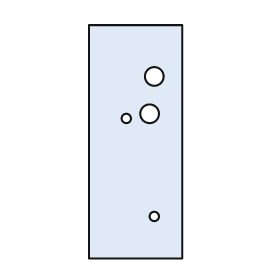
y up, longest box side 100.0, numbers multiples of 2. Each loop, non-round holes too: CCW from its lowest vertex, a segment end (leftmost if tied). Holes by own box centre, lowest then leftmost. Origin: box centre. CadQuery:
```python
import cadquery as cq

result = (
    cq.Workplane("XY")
    .moveTo(-20.0, -50.0)
    .lineTo(20.0, -50.0)
    .lineTo(20.0, 50.0)
    .lineTo(-20.0, 50.0)
    .close()
    .moveTo(8.0, -32.0)
    .circle(2.0)
    .moveTo(-4.0, 10.0)
    .circle(2.0)
    .moveTo(6.0, 12.0)
    .circle(4.0)
    .moveTo(8.0, 28.0)
    .circle(4.0)
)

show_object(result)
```